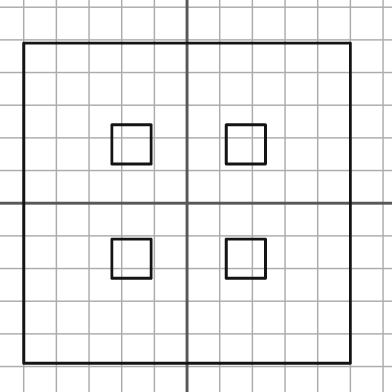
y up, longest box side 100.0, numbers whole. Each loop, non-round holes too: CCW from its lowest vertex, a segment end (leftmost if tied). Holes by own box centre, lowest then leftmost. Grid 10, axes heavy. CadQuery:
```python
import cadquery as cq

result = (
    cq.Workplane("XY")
    .moveTo(-50.0, -49.0)
    .lineTo(50.0, -49.0)
    .lineTo(50.0, 49.0)
    .lineTo(-50.0, 49.0)
    .close()
    .moveTo(-23.0, -23.0)
    .lineTo(-11.0, -23.0)
    .lineTo(-11.0, -11.0)
    .lineTo(-23.0, -11.0)
    .close()
    .moveTo(12.0, -23.0)
    .lineTo(24.0, -23.0)
    .lineTo(24.0, -11.0)
    .lineTo(12.0, -11.0)
    .close()
    .moveTo(-23.0, 12.0)
    .lineTo(-11.0, 12.0)
    .lineTo(-11.0, 24.0)
    .lineTo(-23.0, 24.0)
    .close()
    .moveTo(12.0, 12.0)
    .lineTo(24.0, 12.0)
    .lineTo(24.0, 24.0)
    .lineTo(12.0, 24.0)
    .close()
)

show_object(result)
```